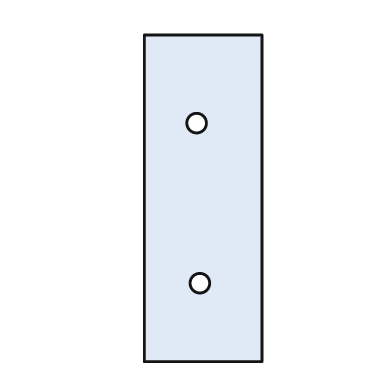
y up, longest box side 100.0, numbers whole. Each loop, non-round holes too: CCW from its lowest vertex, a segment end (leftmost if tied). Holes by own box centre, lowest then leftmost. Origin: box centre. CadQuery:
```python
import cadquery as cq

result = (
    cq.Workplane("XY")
    .moveTo(-18.0, -50.0)
    .lineTo(18.0, -50.0)
    .lineTo(18.0, 50.0)
    .lineTo(-18.0, 50.0)
    .close()
    .moveTo(-1.0, -26.0)
    .circle(3.0)
    .moveTo(-2.0, 23.0)
    .circle(3.0)
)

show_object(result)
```